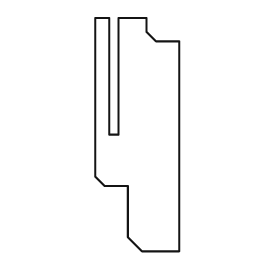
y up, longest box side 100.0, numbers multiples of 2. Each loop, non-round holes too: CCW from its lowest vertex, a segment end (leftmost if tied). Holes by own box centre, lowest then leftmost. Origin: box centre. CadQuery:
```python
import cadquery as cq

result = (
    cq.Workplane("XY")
    .moveTo(2.0, -50.0)
    .lineTo(18.0, -50.0)
    .lineTo(18.0, 40.0)
    .lineTo(8.0, 40.0)
    .lineTo(4.0, 44.0)
    .lineTo(4.0, 50.0)
    .lineTo(-8.0, 50.0)
    .lineTo(-8.0, 0.0)
    .lineTo(-12.0, 0.0)
    .lineTo(-12.0, 50.0)
    .lineTo(-18.0, 50.0)
    .lineTo(-18.0, -18.0)
    .lineTo(-14.0, -22.0)
    .lineTo(-4.0, -22.0)
    .lineTo(-4.0, -44.0)
    .close()
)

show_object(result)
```